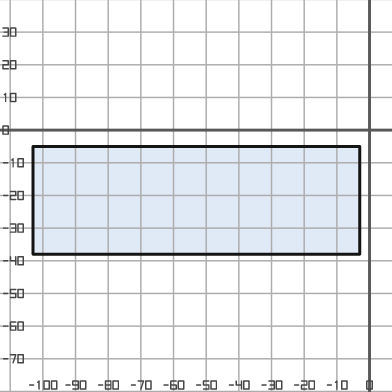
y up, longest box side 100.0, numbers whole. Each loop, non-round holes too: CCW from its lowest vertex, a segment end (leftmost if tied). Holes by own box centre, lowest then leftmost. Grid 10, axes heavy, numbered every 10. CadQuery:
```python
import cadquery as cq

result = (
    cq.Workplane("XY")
    .moveTo(-103.0, -38.0)
    .lineTo(-3.0, -38.0)
    .lineTo(-3.0, -5.0)
    .lineTo(-103.0, -5.0)
    .close()
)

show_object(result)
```